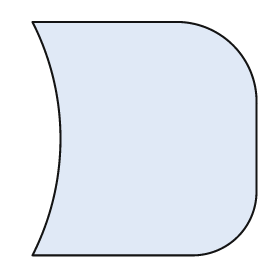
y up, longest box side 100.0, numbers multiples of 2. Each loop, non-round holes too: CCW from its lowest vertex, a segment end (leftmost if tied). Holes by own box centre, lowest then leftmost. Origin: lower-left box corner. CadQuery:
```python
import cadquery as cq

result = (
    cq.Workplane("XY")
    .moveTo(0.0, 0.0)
    .lineTo(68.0, 0.0)
    .threePointArc((88.0, 8.0), (96.0, 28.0))
    .lineTo(96.0, 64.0)
    .threePointArc((86.0, 90.0), (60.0, 100.0))
    .lineTo(0.0, 100.0)
    .threePointArc((12.0, 50.0), (0.0, 0.0))
    .close()
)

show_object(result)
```